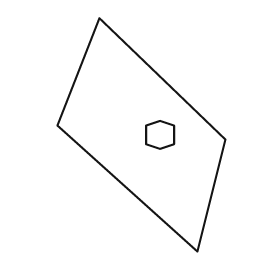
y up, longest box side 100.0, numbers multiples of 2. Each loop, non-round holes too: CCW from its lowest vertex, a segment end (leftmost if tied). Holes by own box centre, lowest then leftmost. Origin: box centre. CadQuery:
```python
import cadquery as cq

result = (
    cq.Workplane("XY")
    .moveTo(24.0, -50.0)
    .lineTo(36.0, -2.0)
    .lineTo(-18.0, 50.0)
    .lineTo(-36.0, 4.0)
    .close()
    .moveTo(8.0, -6.0)
    .lineTo(14.0, -4.0)
    .lineTo(14.0, 4.0)
    .lineTo(8.0, 6.0)
    .lineTo(2.0, 4.0)
    .lineTo(2.0, -4.0)
    .close()
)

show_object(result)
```